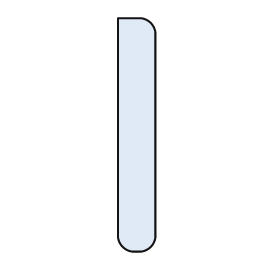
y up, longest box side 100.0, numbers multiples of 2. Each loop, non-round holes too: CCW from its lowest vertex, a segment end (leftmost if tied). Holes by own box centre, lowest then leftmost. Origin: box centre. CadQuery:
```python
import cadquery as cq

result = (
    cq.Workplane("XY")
    .moveTo(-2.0, -50.0)
    .lineTo(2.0, -50.0)
    .threePointArc((6.0, -48.0), (8.0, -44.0))
    .lineTo(8.0, 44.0)
    .threePointArc((6.0, 48.0), (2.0, 50.0))
    .lineTo(-8.0, 50.0)
    .lineTo(-8.0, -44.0)
    .threePointArc((-6.0, -48.0), (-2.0, -50.0))
    .close()
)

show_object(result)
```